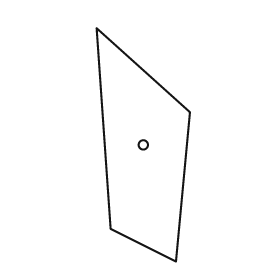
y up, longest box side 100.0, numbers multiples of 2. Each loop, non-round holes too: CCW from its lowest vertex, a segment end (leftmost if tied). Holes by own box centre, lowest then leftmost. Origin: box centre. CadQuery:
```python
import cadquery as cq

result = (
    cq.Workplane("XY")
    .moveTo(14.0, -50.0)
    .lineTo(20.0, 14.0)
    .lineTo(-20.0, 50.0)
    .lineTo(-14.0, -36.0)
    .close()
    .moveTo(0.0, 0.0)
    .circle(2.0)
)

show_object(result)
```